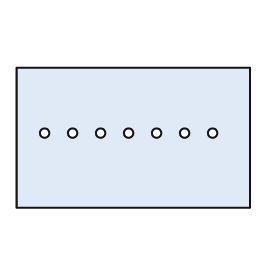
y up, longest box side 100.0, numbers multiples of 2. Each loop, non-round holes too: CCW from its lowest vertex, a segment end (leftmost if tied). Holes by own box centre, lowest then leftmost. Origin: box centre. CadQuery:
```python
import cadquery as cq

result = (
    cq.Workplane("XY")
    .moveTo(-50.0, -30.0)
    .lineTo(50.0, -30.0)
    .lineTo(50.0, 30.0)
    .lineTo(-50.0, 30.0)
    .close()
    .moveTo(-38.0, 2.0)
    .circle(2.0)
    .moveTo(-26.0, 2.0)
    .circle(2.0)
    .moveTo(-14.0, 2.0)
    .circle(2.0)
    .moveTo(-2.0, 2.0)
    .circle(2.0)
    .moveTo(10.0, 2.0)
    .circle(2.0)
    .moveTo(22.0, 2.0)
    .circle(2.0)
    .moveTo(34.0, 2.0)
    .circle(2.0)
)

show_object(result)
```